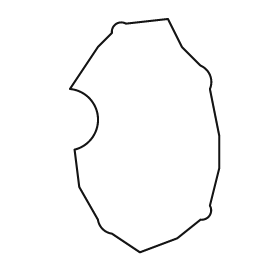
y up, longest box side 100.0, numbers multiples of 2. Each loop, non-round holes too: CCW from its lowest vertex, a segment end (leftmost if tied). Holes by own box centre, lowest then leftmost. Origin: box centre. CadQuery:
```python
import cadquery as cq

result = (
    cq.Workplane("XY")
    .moveTo(-2.0, -50.0)
    .lineTo(14.0, -44.0)
    .lineTo(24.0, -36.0)
    .threePointArc((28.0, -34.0), (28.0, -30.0))
    .lineTo(32.0, -14.0)
    .lineTo(32.0, 0.0)
    .lineTo(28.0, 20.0)
    .threePointArc((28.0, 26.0), (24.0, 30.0))
    .lineTo(16.0, 38.0)
    .lineTo(10.0, 50.0)
    .lineTo(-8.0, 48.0)
    .threePointArc((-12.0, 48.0), (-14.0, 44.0))
    .lineTo(-20.0, 38.0)
    .lineTo(-32.0, 20.0)
    .threePointArc((-20.0, 8.0), (-30.0, -6.0))
    .lineTo(-28.0, -22.0)
    .lineTo(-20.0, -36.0)
    .threePointArc((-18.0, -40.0), (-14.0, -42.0))
    .close()
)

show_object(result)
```